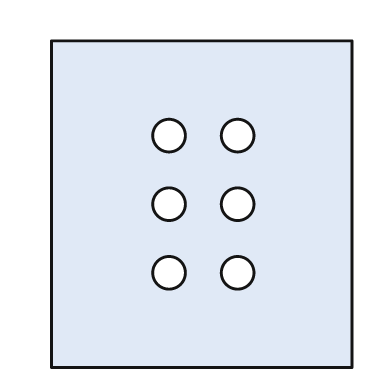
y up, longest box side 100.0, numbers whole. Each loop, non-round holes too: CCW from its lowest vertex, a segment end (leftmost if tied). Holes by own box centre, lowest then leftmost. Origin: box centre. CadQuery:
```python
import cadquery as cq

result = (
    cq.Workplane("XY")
    .moveTo(-46.0, -50.0)
    .lineTo(46.0, -50.0)
    .lineTo(46.0, 50.0)
    .lineTo(-46.0, 50.0)
    .close()
    .moveTo(-10.0, -21.0)
    .circle(5.0)
    .moveTo(11.0, -21.0)
    .circle(5.0)
    .moveTo(-10.0, 0.0)
    .circle(5.0)
    .moveTo(11.0, 0.0)
    .circle(5.0)
    .moveTo(-10.0, 21.0)
    .circle(5.0)
    .moveTo(11.0, 21.0)
    .circle(5.0)
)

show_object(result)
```